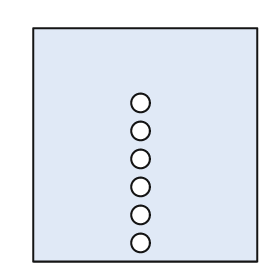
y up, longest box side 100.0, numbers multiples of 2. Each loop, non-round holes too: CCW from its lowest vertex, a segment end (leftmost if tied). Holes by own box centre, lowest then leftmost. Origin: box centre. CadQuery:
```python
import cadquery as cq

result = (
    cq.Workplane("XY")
    .moveTo(-48.0, -50.0)
    .lineTo(48.0, -50.0)
    .lineTo(48.0, 50.0)
    .lineTo(-48.0, 50.0)
    .close()
    .moveTo(-2.0, -42.0)
    .circle(4.0)
    .moveTo(-2.0, -30.0)
    .circle(4.0)
    .moveTo(-2.0, -18.0)
    .circle(4.0)
    .moveTo(-2.0, -6.0)
    .circle(4.0)
    .moveTo(-2.0, 6.0)
    .circle(4.0)
    .moveTo(-2.0, 18.0)
    .circle(4.0)
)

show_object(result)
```